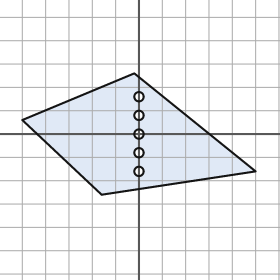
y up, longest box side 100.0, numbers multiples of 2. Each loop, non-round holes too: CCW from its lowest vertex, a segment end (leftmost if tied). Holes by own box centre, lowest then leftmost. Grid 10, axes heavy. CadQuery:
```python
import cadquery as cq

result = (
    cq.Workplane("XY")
    .moveTo(-16.0, -26.0)
    .lineTo(50.0, -16.0)
    .lineTo(-2.0, 26.0)
    .lineTo(-50.0, 6.0)
    .close()
    .moveTo(0.0, -16.0)
    .circle(2.0)
    .moveTo(0.0, -8.0)
    .circle(2.0)
    .moveTo(0.0, 0.0)
    .circle(2.0)
    .moveTo(0.0, 8.0)
    .circle(2.0)
    .moveTo(0.0, 16.0)
    .circle(2.0)
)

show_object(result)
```